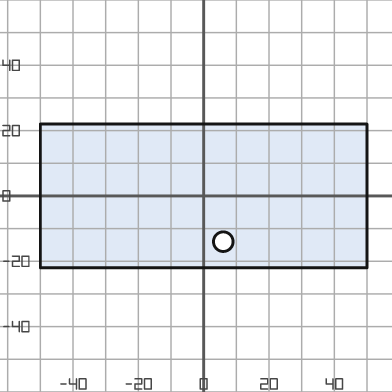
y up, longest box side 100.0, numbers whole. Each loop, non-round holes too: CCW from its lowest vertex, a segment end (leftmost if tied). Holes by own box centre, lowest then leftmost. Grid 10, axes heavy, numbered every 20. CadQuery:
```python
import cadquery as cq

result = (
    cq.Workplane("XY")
    .moveTo(-50.0, -22.0)
    .lineTo(50.0, -22.0)
    .lineTo(50.0, 22.0)
    .lineTo(-50.0, 22.0)
    .close()
    .moveTo(6.0, -14.0)
    .circle(3.0)
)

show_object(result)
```